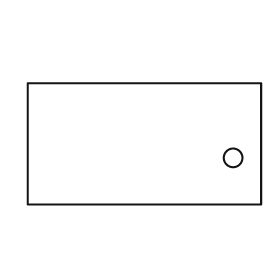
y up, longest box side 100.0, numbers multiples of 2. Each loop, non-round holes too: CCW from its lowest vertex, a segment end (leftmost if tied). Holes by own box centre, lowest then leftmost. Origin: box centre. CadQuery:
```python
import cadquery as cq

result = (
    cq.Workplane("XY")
    .moveTo(-50.0, -26.0)
    .lineTo(50.0, -26.0)
    .lineTo(50.0, 26.0)
    .lineTo(-50.0, 26.0)
    .close()
    .moveTo(38.0, -6.0)
    .circle(4.0)
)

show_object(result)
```